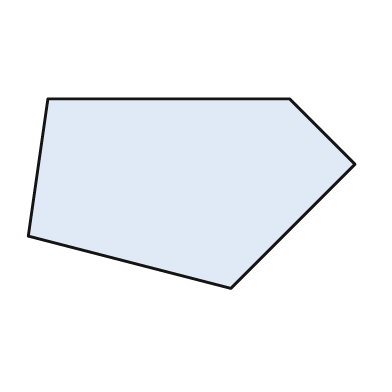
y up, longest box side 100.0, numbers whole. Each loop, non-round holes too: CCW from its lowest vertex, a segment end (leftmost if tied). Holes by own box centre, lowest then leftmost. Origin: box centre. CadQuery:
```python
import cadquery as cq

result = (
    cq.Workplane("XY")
    .moveTo(12.0, -29.0)
    .lineTo(50.0, 9.0)
    .lineTo(30.0, 29.0)
    .lineTo(-44.0, 29.0)
    .lineTo(-50.0, -13.0)
    .close()
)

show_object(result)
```